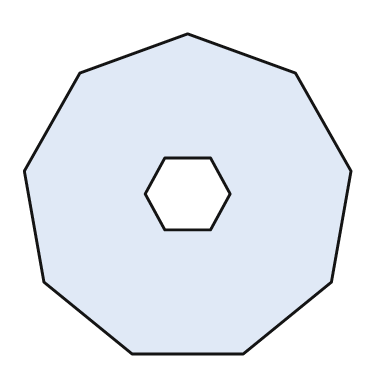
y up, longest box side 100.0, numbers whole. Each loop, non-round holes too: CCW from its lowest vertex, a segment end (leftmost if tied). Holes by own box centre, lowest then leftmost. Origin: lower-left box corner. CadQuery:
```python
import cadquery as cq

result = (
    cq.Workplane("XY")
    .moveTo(33.0, 0.0)
    .lineTo(67.0, 0.0)
    .lineTo(94.0, 22.0)
    .lineTo(100.0, 56.0)
    .lineTo(83.0, 86.0)
    .lineTo(50.0, 98.0)
    .lineTo(17.0, 86.0)
    .lineTo(0.0, 56.0)
    .lineTo(6.0, 22.0)
    .close()
    .moveTo(43.0, 38.0)
    .lineTo(57.0, 38.0)
    .lineTo(63.0, 49.0)
    .lineTo(57.0, 60.0)
    .lineTo(43.0, 60.0)
    .lineTo(37.0, 49.0)
    .close()
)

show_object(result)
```